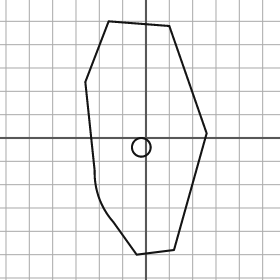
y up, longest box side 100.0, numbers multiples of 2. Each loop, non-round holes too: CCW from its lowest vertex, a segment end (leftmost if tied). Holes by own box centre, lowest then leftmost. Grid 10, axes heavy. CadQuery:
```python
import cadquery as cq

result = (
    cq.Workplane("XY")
    .moveTo(-4.0, -50.0)
    .lineTo(12.0, -48.0)
    .lineTo(26.0, 2.0)
    .lineTo(10.0, 48.0)
    .lineTo(-16.0, 50.0)
    .lineTo(-26.0, 24.0)
    .lineTo(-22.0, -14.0)
    .threePointArc((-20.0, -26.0), (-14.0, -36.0))
    .close()
    .moveTo(-2.0, -4.0)
    .circle(4.0)
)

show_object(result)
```